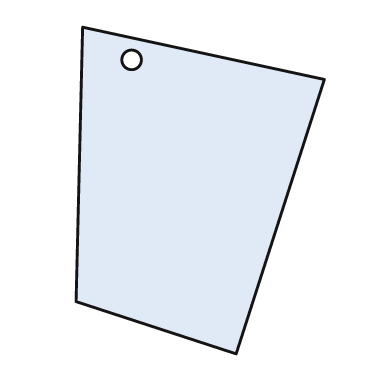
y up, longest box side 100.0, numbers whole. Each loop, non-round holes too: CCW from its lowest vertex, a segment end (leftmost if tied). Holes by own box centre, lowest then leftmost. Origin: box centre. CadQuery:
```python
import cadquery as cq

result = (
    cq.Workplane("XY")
    .moveTo(11.0, -50.0)
    .lineTo(38.0, 34.0)
    .lineTo(-36.0, 50.0)
    .lineTo(-38.0, -34.0)
    .close()
    .moveTo(-21.0, 40.0)
    .circle(3.0)
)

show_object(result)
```